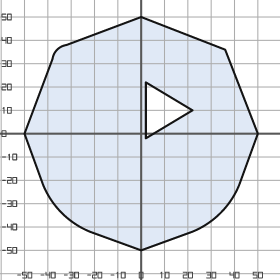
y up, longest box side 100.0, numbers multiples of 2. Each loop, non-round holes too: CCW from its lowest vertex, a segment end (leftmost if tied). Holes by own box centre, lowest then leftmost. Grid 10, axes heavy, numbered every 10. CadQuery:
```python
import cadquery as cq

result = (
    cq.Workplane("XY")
    .moveTo(0.0, -50.0)
    .lineTo(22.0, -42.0)
    .threePointArc((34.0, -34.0), (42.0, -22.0))
    .lineTo(50.0, 0.0)
    .lineTo(36.0, 36.0)
    .lineTo(0.0, 50.0)
    .lineTo(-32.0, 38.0)
    .threePointArc((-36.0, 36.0), (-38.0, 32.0))
    .lineTo(-50.0, 0.0)
    .lineTo(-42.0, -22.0)
    .threePointArc((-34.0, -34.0), (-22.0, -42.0))
    .close()
    .moveTo(2.0, -2.0)
    .lineTo(22.0, 10.0)
    .lineTo(2.0, 22.0)
    .close()
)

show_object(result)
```